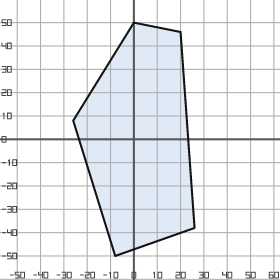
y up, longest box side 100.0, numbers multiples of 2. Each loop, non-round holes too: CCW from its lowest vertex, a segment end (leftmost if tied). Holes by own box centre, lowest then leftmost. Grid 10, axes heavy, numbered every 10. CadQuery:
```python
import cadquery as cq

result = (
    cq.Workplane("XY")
    .moveTo(-8.0, -50.0)
    .lineTo(26.0, -38.0)
    .lineTo(20.0, 46.0)
    .lineTo(0.0, 50.0)
    .lineTo(-26.0, 8.0)
    .close()
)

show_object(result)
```